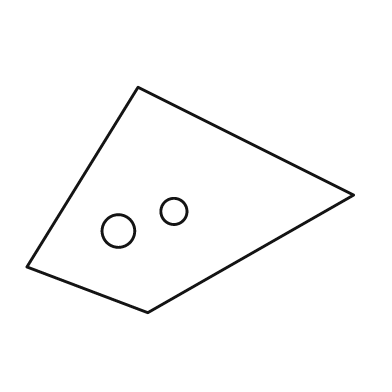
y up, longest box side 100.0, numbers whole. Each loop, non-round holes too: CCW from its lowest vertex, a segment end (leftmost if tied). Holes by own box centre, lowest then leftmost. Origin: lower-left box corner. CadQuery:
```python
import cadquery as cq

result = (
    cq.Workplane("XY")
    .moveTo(37.0, 0.0)
    .lineTo(100.0, 36.0)
    .lineTo(34.0, 69.0)
    .lineTo(0.0, 14.0)
    .close()
    .moveTo(28.0, 25.0)
    .circle(5.0)
    .moveTo(45.0, 31.0)
    .circle(4.0)
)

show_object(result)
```